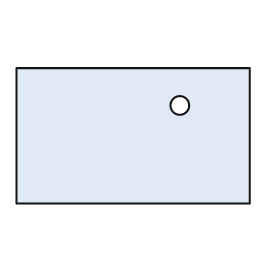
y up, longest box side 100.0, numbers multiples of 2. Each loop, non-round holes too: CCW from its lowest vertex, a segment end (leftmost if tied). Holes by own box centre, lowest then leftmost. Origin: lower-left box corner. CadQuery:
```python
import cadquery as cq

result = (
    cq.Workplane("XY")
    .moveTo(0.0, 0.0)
    .lineTo(100.0, 0.0)
    .lineTo(100.0, 58.0)
    .lineTo(0.0, 58.0)
    .close()
    .moveTo(70.0, 42.0)
    .circle(4.0)
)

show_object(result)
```